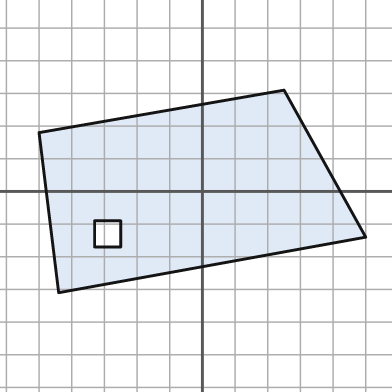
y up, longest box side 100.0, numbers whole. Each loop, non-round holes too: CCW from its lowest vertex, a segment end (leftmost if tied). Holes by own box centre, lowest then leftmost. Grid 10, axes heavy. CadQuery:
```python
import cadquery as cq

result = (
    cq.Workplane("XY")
    .moveTo(-44.0, -31.0)
    .lineTo(50.0, -14.0)
    .lineTo(25.0, 31.0)
    .lineTo(-50.0, 18.0)
    .close()
    .moveTo(-33.0, -17.0)
    .lineTo(-25.0, -17.0)
    .lineTo(-25.0, -9.0)
    .lineTo(-33.0, -9.0)
    .close()
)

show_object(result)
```